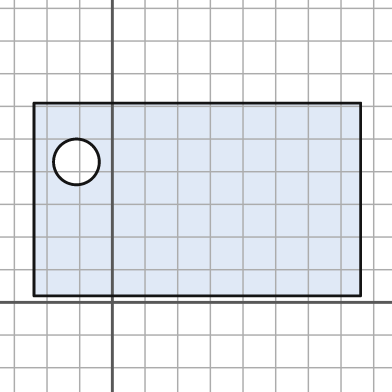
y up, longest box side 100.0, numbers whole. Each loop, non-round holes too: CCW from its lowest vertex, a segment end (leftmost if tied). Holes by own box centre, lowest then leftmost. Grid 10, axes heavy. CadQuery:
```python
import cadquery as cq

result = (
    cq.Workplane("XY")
    .moveTo(-24.0, 2.0)
    .lineTo(76.0, 2.0)
    .lineTo(76.0, 61.0)
    .lineTo(-24.0, 61.0)
    .close()
    .moveTo(-11.0, 43.0)
    .circle(7.0)
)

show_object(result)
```